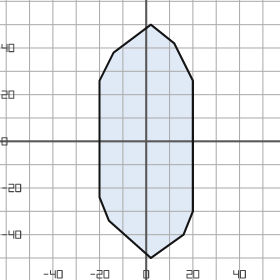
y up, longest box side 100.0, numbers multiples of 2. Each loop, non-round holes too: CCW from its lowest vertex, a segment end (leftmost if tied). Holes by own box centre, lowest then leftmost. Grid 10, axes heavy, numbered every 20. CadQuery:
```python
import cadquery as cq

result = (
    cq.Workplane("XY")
    .moveTo(2.0, -50.0)
    .lineTo(16.0, -40.0)
    .lineTo(20.0, -30.0)
    .lineTo(20.0, 26.0)
    .lineTo(12.0, 42.0)
    .lineTo(2.0, 50.0)
    .lineTo(-14.0, 38.0)
    .lineTo(-20.0, 26.0)
    .lineTo(-20.0, -24.0)
    .lineTo(-16.0, -34.0)
    .close()
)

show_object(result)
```